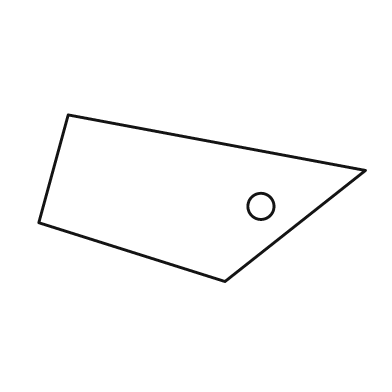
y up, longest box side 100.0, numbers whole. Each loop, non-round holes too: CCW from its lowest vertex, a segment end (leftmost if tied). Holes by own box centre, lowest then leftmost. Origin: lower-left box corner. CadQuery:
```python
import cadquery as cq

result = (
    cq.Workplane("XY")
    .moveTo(57.0, 0.0)
    .lineTo(100.0, 34.0)
    .lineTo(9.0, 51.0)
    .lineTo(0.0, 18.0)
    .close()
    .moveTo(68.0, 23.0)
    .circle(4.0)
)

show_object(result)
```